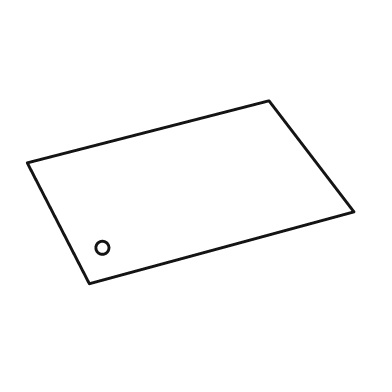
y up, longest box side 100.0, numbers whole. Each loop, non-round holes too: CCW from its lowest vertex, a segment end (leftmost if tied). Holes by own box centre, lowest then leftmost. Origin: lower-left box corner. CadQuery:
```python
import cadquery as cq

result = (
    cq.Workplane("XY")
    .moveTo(19.0, 0.0)
    .lineTo(100.0, 22.0)
    .lineTo(74.0, 56.0)
    .lineTo(0.0, 37.0)
    .close()
    .moveTo(23.0, 11.0)
    .circle(2.0)
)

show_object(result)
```